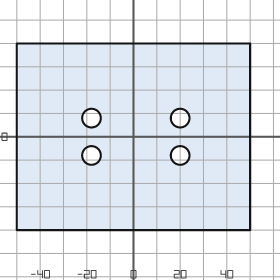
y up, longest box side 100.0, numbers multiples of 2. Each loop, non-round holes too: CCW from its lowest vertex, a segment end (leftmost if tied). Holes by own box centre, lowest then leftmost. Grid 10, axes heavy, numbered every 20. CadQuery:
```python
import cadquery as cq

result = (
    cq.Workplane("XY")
    .moveTo(-50.0, -40.0)
    .lineTo(50.0, -40.0)
    .lineTo(50.0, 40.0)
    .lineTo(-50.0, 40.0)
    .close()
    .moveTo(-18.0, -8.0)
    .circle(4.0)
    .moveTo(20.0, -8.0)
    .circle(4.0)
    .moveTo(-18.0, 8.0)
    .circle(4.0)
    .moveTo(20.0, 8.0)
    .circle(4.0)
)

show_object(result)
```